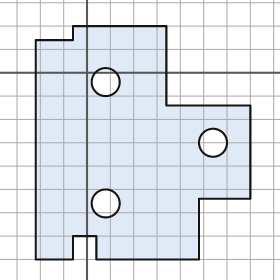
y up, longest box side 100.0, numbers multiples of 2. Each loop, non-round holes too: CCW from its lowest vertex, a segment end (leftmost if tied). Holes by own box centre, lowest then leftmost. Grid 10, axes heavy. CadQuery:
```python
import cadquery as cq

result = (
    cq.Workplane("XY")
    .moveTo(-22.0, -80.0)
    .lineTo(-6.0, -80.0)
    .lineTo(-6.0, -70.0)
    .lineTo(4.0, -70.0)
    .lineTo(4.0, -80.0)
    .lineTo(48.0, -80.0)
    .lineTo(48.0, -54.0)
    .lineTo(70.0, -54.0)
    .lineTo(70.0, -14.0)
    .lineTo(34.0, -14.0)
    .lineTo(34.0, 20.0)
    .lineTo(-6.0, 20.0)
    .lineTo(-6.0, 14.0)
    .lineTo(-22.0, 14.0)
    .close()
    .moveTo(8.0, -56.0)
    .circle(6.0)
    .moveTo(54.0, -30.0)
    .circle(6.0)
    .moveTo(8.0, -4.0)
    .circle(6.0)
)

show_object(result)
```